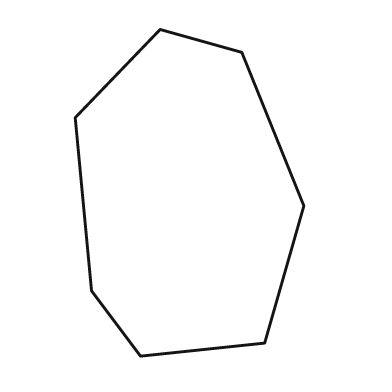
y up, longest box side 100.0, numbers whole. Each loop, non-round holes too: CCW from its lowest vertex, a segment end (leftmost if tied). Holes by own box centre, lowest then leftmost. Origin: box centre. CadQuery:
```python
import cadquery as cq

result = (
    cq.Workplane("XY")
    .moveTo(-15.0, -50.0)
    .lineTo(23.0, -46.0)
    .lineTo(35.0, -4.0)
    .lineTo(16.0, 43.0)
    .lineTo(-9.0, 50.0)
    .lineTo(-35.0, 23.0)
    .lineTo(-30.0, -30.0)
    .close()
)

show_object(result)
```